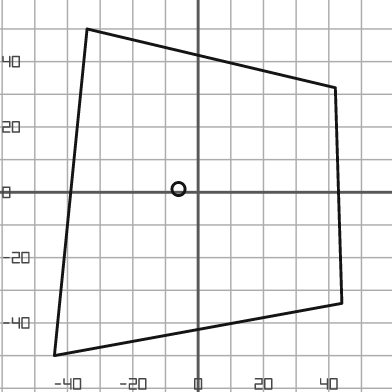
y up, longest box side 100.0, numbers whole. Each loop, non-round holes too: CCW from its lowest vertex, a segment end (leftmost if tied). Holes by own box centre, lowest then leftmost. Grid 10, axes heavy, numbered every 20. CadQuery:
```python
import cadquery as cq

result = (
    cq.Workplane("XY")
    .moveTo(-44.0, -50.0)
    .lineTo(44.0, -34.0)
    .lineTo(42.0, 32.0)
    .lineTo(-34.0, 50.0)
    .close()
    .moveTo(-6.0, 1.0)
    .circle(2.0)
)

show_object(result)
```